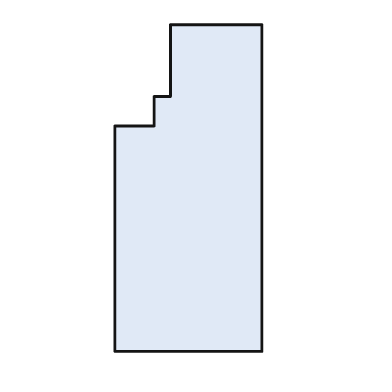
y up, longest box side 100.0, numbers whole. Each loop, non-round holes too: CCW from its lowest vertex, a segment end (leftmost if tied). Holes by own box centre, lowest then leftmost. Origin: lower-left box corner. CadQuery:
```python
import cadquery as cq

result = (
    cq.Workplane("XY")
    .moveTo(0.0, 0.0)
    .lineTo(45.0, 0.0)
    .lineTo(45.0, 100.0)
    .lineTo(17.0, 100.0)
    .lineTo(17.0, 78.0)
    .lineTo(12.0, 78.0)
    .lineTo(12.0, 69.0)
    .lineTo(0.0, 69.0)
    .close()
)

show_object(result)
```